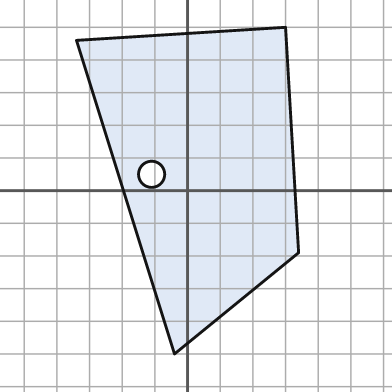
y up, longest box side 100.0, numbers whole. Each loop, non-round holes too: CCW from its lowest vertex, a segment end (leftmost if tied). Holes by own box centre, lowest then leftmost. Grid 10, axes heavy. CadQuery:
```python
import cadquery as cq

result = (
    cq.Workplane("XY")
    .moveTo(-4.0, -50.0)
    .lineTo(34.0, -19.0)
    .lineTo(30.0, 50.0)
    .lineTo(-34.0, 46.0)
    .close()
    .moveTo(-11.0, 5.0)
    .circle(4.0)
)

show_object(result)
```